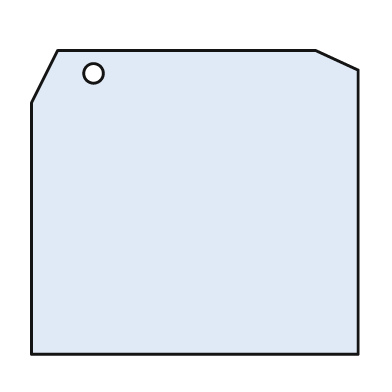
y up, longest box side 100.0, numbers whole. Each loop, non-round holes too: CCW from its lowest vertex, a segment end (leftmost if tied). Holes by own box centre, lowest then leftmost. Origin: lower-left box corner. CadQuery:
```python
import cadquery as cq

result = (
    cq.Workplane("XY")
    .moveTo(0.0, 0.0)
    .lineTo(100.0, 0.0)
    .lineTo(100.0, 87.0)
    .lineTo(87.0, 93.0)
    .lineTo(8.0, 93.0)
    .lineTo(0.0, 77.0)
    .close()
    .moveTo(19.0, 86.0)
    .circle(3.0)
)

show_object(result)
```